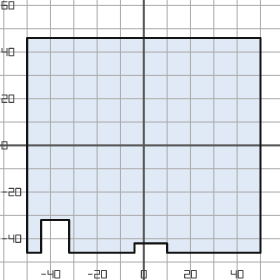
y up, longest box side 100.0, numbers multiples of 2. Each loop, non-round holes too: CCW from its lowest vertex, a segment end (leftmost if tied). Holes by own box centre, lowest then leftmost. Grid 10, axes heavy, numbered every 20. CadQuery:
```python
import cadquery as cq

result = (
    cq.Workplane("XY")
    .moveTo(-50.0, -46.0)
    .lineTo(-44.0, -46.0)
    .lineTo(-44.0, -32.0)
    .lineTo(-32.0, -32.0)
    .lineTo(-32.0, -46.0)
    .lineTo(-4.0, -46.0)
    .lineTo(-4.0, -42.0)
    .lineTo(10.0, -42.0)
    .lineTo(10.0, -46.0)
    .lineTo(50.0, -46.0)
    .lineTo(50.0, 46.0)
    .lineTo(-50.0, 46.0)
    .close()
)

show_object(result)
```